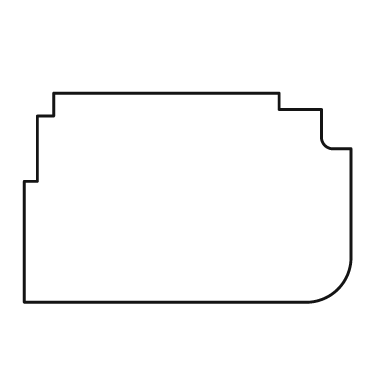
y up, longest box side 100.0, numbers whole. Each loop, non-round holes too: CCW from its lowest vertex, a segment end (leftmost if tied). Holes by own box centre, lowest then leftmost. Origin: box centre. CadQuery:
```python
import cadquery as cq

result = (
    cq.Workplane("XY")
    .moveTo(-50.0, -32.0)
    .lineTo(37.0, -32.0)
    .threePointArc((46.0, -28.0), (50.0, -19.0))
    .lineTo(50.0, 15.0)
    .lineTo(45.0, 15.0)
    .threePointArc((42.0, 16.0), (41.0, 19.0))
    .lineTo(41.0, 27.0)
    .lineTo(28.0, 27.0)
    .lineTo(28.0, 32.0)
    .lineTo(-41.0, 32.0)
    .lineTo(-41.0, 25.0)
    .lineTo(-46.0, 25.0)
    .lineTo(-46.0, 5.0)
    .lineTo(-50.0, 5.0)
    .close()
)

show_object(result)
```